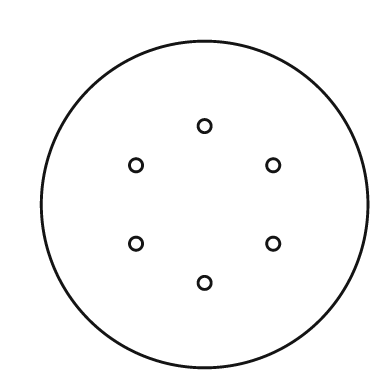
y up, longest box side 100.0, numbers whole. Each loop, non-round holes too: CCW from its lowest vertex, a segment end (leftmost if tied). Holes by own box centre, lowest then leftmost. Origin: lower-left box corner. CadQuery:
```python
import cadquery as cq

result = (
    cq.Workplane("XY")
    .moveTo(50.0, 50.0)
    .circle(50.0)
    .moveTo(50.0, 26.0)
    .circle(2.0)
    .moveTo(29.0, 38.0)
    .circle(2.0)
    .moveTo(71.0, 38.0)
    .circle(2.0)
    .moveTo(29.0, 62.0)
    .circle(2.0)
    .moveTo(71.0, 62.0)
    .circle(2.0)
    .moveTo(50.0, 74.0)
    .circle(2.0)
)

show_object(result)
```